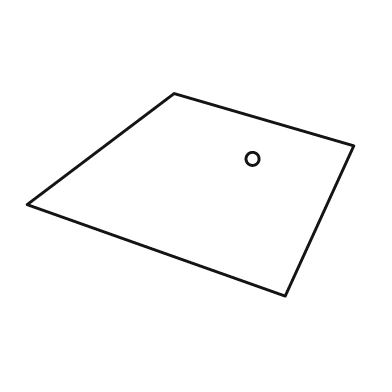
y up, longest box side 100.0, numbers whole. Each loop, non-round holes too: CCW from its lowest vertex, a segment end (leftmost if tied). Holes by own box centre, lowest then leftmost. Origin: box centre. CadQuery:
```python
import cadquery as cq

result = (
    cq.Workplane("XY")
    .moveTo(29.0, -31.0)
    .lineTo(50.0, 15.0)
    .lineTo(-5.0, 31.0)
    .lineTo(-50.0, -3.0)
    .close()
    .moveTo(19.0, 11.0)
    .circle(2.0)
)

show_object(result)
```